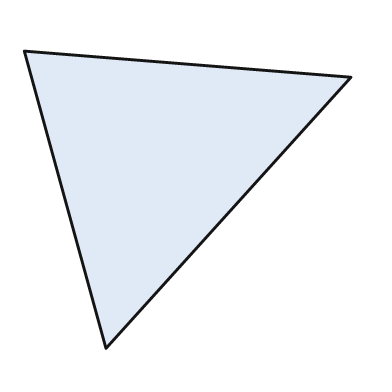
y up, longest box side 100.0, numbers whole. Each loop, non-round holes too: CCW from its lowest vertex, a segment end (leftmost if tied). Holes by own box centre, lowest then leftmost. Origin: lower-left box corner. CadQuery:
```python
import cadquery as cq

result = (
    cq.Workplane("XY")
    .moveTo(25.0, 0.0)
    .lineTo(100.0, 83.0)
    .lineTo(0.0, 91.0)
    .close()
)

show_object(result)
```